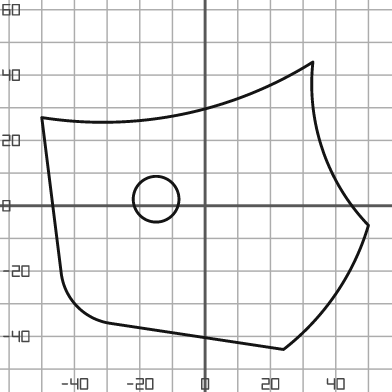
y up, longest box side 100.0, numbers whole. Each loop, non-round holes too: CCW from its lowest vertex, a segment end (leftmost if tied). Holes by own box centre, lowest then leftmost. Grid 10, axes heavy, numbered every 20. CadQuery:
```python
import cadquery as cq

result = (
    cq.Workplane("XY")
    .moveTo(24.0, -44.0)
    .threePointArc((40.0, -27.0), (50.0, -6.0))
    .threePointArc((36.0, 17.0), (33.0, 44.0))
    .threePointArc((-7.0, 28.0), (-50.0, 27.0))
    .lineTo(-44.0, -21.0)
    .threePointArc((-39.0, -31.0), (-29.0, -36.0))
    .close()
    .moveTo(-15.0, 2.0)
    .circle(7.0)
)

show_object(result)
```